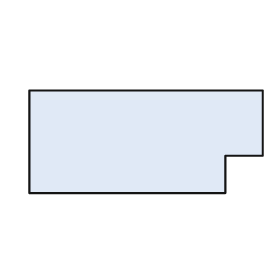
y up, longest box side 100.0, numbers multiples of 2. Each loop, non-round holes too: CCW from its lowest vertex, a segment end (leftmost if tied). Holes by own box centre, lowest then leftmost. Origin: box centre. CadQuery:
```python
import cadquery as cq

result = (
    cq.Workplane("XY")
    .moveTo(-50.0, -22.0)
    .lineTo(34.0, -22.0)
    .lineTo(34.0, -6.0)
    .lineTo(50.0, -6.0)
    .lineTo(50.0, 22.0)
    .lineTo(-50.0, 22.0)
    .close()
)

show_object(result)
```